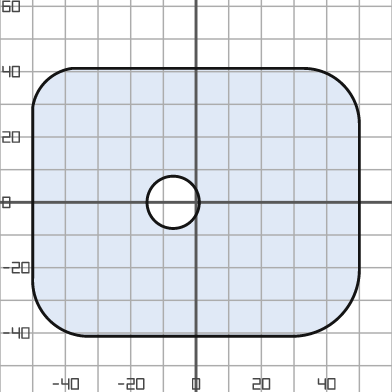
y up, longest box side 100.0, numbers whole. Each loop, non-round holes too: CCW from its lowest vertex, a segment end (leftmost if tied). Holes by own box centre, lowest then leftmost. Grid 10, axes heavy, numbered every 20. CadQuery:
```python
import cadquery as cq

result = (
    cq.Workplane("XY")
    .moveTo(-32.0, -41.0)
    .lineTo(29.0, -41.0)
    .threePointArc((44.0, -35.0), (50.0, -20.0))
    .lineTo(50.0, 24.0)
    .threePointArc((45.0, 36.0), (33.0, 41.0))
    .lineTo(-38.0, 41.0)
    .threePointArc((-46.0, 37.0), (-50.0, 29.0))
    .lineTo(-50.0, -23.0)
    .threePointArc((-45.0, -36.0), (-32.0, -41.0))
    .close()
    .moveTo(-7.0, 0.0)
    .circle(8.0)
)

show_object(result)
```